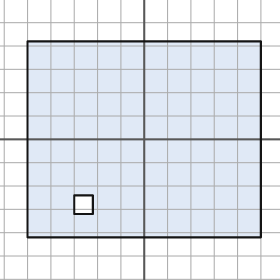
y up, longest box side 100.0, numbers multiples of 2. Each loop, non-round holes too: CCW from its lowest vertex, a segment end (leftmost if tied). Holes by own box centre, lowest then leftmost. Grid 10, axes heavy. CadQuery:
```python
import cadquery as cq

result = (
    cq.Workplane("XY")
    .moveTo(-50.0, -42.0)
    .lineTo(50.0, -42.0)
    .lineTo(50.0, 42.0)
    .lineTo(-50.0, 42.0)
    .close()
    .moveTo(-30.0, -32.0)
    .lineTo(-22.0, -32.0)
    .lineTo(-22.0, -24.0)
    .lineTo(-30.0, -24.0)
    .close()
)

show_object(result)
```